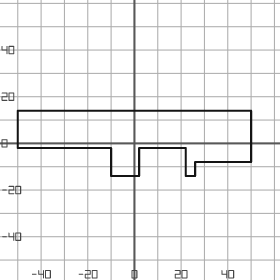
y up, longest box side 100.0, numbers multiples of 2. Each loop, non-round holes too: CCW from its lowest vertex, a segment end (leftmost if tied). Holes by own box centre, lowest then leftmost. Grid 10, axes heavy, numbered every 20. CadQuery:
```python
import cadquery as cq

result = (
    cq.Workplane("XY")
    .moveTo(-10.0, -14.0)
    .lineTo(2.0, -14.0)
    .lineTo(2.0, -2.0)
    .lineTo(22.0, -2.0)
    .lineTo(22.0, -14.0)
    .lineTo(26.0, -14.0)
    .lineTo(26.0, -8.0)
    .lineTo(50.0, -8.0)
    .lineTo(50.0, 14.0)
    .lineTo(-50.0, 14.0)
    .lineTo(-50.0, -2.0)
    .lineTo(-10.0, -2.0)
    .close()
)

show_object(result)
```